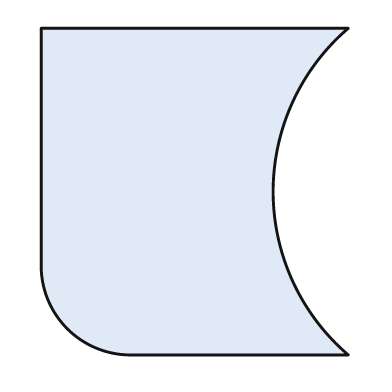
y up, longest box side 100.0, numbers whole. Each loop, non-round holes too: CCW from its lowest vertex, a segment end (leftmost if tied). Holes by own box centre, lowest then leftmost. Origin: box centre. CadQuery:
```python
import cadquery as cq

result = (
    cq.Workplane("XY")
    .moveTo(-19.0, -50.0)
    .lineTo(47.0, -50.0)
    .threePointArc((24.0, 0.0), (47.0, 50.0))
    .lineTo(-47.0, 50.0)
    .lineTo(-47.0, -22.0)
    .threePointArc((-39.0, -42.0), (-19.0, -50.0))
    .close()
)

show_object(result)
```